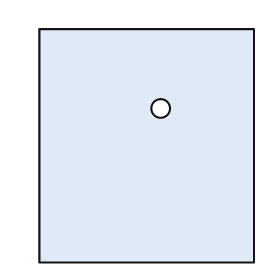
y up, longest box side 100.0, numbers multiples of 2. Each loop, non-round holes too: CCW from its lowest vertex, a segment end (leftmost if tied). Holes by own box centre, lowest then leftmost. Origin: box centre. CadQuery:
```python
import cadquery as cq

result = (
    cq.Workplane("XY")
    .moveTo(-46.0, -50.0)
    .lineTo(46.0, -50.0)
    .lineTo(46.0, 50.0)
    .lineTo(-46.0, 50.0)
    .close()
    .moveTo(6.0, 16.0)
    .circle(4.0)
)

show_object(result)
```